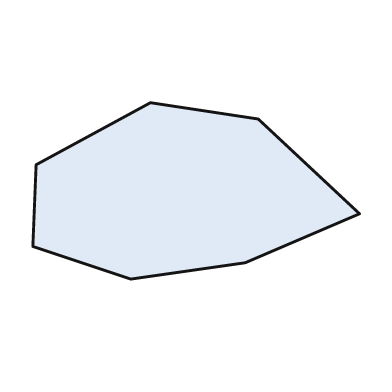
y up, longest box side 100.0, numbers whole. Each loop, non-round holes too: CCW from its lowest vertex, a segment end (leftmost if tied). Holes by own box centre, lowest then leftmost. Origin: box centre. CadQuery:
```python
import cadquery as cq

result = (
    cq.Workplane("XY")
    .moveTo(-20.0, -27.0)
    .lineTo(15.0, -22.0)
    .lineTo(50.0, -7.0)
    .lineTo(19.0, 22.0)
    .lineTo(-14.0, 27.0)
    .lineTo(-49.0, 8.0)
    .lineTo(-50.0, -17.0)
    .close()
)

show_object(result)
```